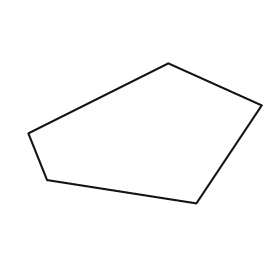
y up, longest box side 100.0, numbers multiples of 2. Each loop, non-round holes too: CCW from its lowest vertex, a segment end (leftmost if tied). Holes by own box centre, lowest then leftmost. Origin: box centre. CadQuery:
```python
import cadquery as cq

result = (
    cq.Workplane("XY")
    .moveTo(22.0, -30.0)
    .lineTo(50.0, 12.0)
    .lineTo(10.0, 30.0)
    .lineTo(-50.0, 0.0)
    .lineTo(-42.0, -20.0)
    .close()
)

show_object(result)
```